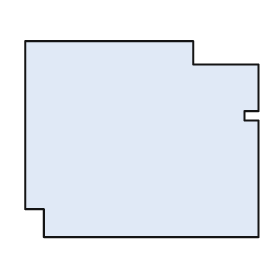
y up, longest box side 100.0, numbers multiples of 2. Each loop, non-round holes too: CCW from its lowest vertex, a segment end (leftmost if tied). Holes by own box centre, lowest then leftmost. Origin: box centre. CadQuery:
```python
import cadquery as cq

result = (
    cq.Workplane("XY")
    .moveTo(-42.0, -42.0)
    .lineTo(50.0, -42.0)
    .lineTo(50.0, 8.0)
    .lineTo(44.0, 8.0)
    .lineTo(44.0, 12.0)
    .lineTo(50.0, 12.0)
    .lineTo(50.0, 32.0)
    .lineTo(22.0, 32.0)
    .lineTo(22.0, 42.0)
    .lineTo(-50.0, 42.0)
    .lineTo(-50.0, -30.0)
    .lineTo(-42.0, -30.0)
    .close()
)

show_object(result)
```